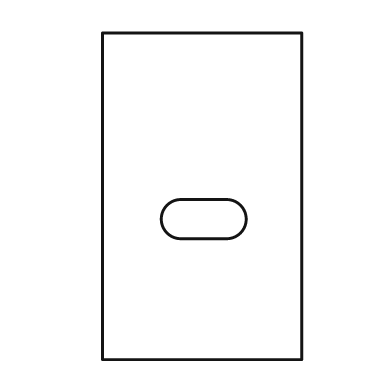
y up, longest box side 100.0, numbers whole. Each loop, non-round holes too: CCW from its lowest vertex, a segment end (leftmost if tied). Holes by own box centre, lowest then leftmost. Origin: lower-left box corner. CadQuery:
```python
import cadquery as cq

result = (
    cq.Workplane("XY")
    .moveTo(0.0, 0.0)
    .lineTo(61.0, 0.0)
    .lineTo(61.0, 100.0)
    .lineTo(0.0, 100.0)
    .close()
    .moveTo(24.0, 37.0)
    .lineTo(38.0, 37.0)
    .threePointArc((44.0, 43.0), (38.0, 49.0))
    .lineTo(24.0, 49.0)
    .threePointArc((18.0, 43.0), (24.0, 37.0))
    .close()
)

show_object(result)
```